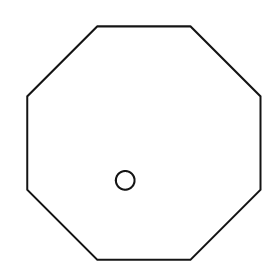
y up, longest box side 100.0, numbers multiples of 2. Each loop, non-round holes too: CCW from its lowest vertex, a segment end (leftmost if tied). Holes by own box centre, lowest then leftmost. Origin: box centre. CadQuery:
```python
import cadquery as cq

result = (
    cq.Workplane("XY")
    .moveTo(-20.0, -50.0)
    .lineTo(20.0, -50.0)
    .lineTo(50.0, -20.0)
    .lineTo(50.0, 20.0)
    .lineTo(20.0, 50.0)
    .lineTo(-20.0, 50.0)
    .lineTo(-50.0, 20.0)
    .lineTo(-50.0, -20.0)
    .close()
    .moveTo(-8.0, -16.0)
    .circle(4.0)
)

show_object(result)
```